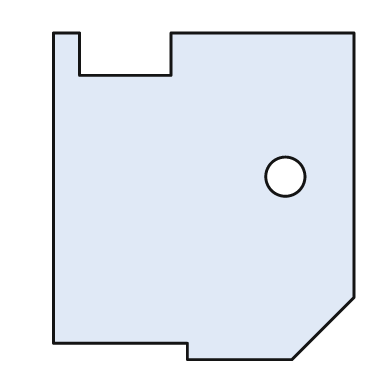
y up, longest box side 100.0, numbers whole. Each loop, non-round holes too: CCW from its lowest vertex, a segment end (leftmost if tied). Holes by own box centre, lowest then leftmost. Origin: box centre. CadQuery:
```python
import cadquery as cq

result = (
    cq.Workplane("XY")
    .moveTo(-5.0, -50.0)
    .lineTo(27.0, -50.0)
    .lineTo(46.0, -31.0)
    .lineTo(46.0, 50.0)
    .lineTo(-10.0, 50.0)
    .lineTo(-10.0, 37.0)
    .lineTo(-38.0, 37.0)
    .lineTo(-38.0, 50.0)
    .lineTo(-46.0, 50.0)
    .lineTo(-46.0, -45.0)
    .lineTo(-5.0, -45.0)
    .close()
    .moveTo(25.0, 6.0)
    .circle(6.0)
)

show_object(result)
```